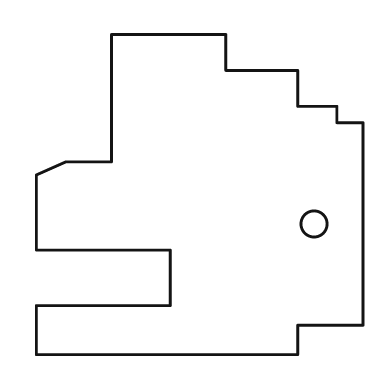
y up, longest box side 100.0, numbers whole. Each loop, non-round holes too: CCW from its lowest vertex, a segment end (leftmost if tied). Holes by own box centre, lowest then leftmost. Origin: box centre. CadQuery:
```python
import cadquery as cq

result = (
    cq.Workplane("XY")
    .moveTo(-50.0, -49.0)
    .lineTo(30.0, -49.0)
    .lineTo(30.0, -40.0)
    .lineTo(50.0, -40.0)
    .lineTo(50.0, 22.0)
    .lineTo(42.0, 22.0)
    .lineTo(42.0, 27.0)
    .lineTo(30.0, 27.0)
    .lineTo(30.0, 38.0)
    .lineTo(8.0, 38.0)
    .lineTo(8.0, 49.0)
    .lineTo(-27.0, 49.0)
    .lineTo(-27.0, 10.0)
    .lineTo(-41.0, 10.0)
    .lineTo(-50.0, 6.0)
    .lineTo(-50.0, -17.0)
    .lineTo(-9.0, -17.0)
    .lineTo(-9.0, -34.0)
    .lineTo(-50.0, -34.0)
    .close()
    .moveTo(35.0, -9.0)
    .circle(4.0)
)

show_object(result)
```